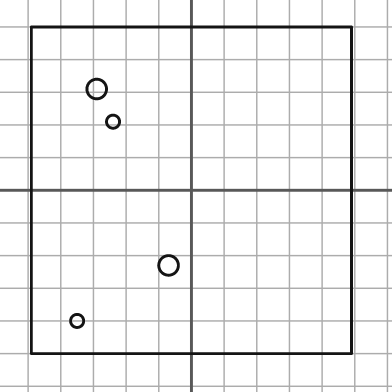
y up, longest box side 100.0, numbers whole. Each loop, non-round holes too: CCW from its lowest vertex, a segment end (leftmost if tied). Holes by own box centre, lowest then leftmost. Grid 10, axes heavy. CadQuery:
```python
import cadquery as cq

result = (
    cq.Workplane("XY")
    .moveTo(-49.0, -50.0)
    .lineTo(49.0, -50.0)
    .lineTo(49.0, 50.0)
    .lineTo(-49.0, 50.0)
    .close()
    .moveTo(-35.0, -40.0)
    .circle(2.0)
    .moveTo(-7.0, -23.0)
    .circle(3.0)
    .moveTo(-24.0, 21.0)
    .circle(2.0)
    .moveTo(-29.0, 31.0)
    .circle(3.0)
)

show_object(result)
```